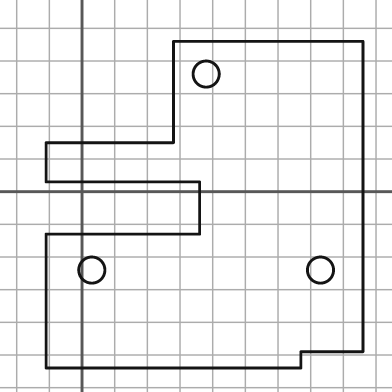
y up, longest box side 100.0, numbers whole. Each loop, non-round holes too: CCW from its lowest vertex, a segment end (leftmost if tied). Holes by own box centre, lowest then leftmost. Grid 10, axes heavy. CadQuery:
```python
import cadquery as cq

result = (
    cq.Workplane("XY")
    .moveTo(-11.0, -54.0)
    .lineTo(67.0, -54.0)
    .lineTo(67.0, -49.0)
    .lineTo(86.0, -49.0)
    .lineTo(86.0, 46.0)
    .lineTo(28.0, 46.0)
    .lineTo(28.0, 15.0)
    .lineTo(-11.0, 15.0)
    .lineTo(-11.0, 3.0)
    .lineTo(36.0, 3.0)
    .lineTo(36.0, -13.0)
    .lineTo(-11.0, -13.0)
    .close()
    .moveTo(3.0, -24.0)
    .circle(4.0)
    .moveTo(73.0, -24.0)
    .circle(4.0)
    .moveTo(38.0, 36.0)
    .circle(4.0)
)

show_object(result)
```